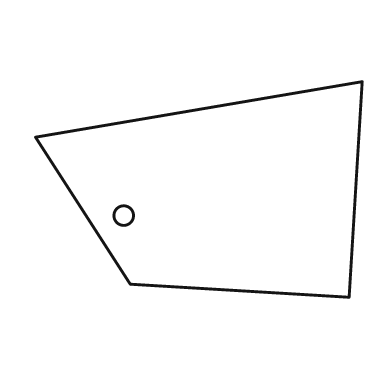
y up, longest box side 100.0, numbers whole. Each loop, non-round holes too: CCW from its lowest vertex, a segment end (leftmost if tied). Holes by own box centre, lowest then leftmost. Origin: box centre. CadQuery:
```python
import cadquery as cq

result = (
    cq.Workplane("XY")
    .moveTo(46.0, -33.0)
    .lineTo(50.0, 33.0)
    .lineTo(-50.0, 16.0)
    .lineTo(-21.0, -29.0)
    .close()
    .moveTo(-23.0, -8.0)
    .circle(3.0)
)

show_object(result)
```